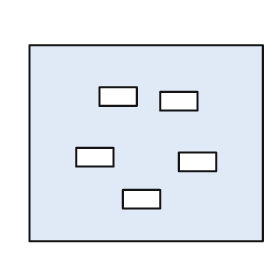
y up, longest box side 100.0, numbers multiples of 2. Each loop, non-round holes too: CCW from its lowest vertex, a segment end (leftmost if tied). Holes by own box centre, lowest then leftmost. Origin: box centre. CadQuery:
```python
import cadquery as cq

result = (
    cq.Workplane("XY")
    .moveTo(-50.0, -42.0)
    .lineTo(50.0, -42.0)
    .lineTo(50.0, 42.0)
    .lineTo(-50.0, 42.0)
    .close()
    .moveTo(-10.0, -28.0)
    .lineTo(6.0, -28.0)
    .lineTo(6.0, -20.0)
    .lineTo(-10.0, -20.0)
    .close()
    .moveTo(14.0, -12.0)
    .lineTo(30.0, -12.0)
    .lineTo(30.0, -4.0)
    .lineTo(14.0, -4.0)
    .close()
    .moveTo(-30.0, -10.0)
    .lineTo(-14.0, -10.0)
    .lineTo(-14.0, -2.0)
    .lineTo(-30.0, -2.0)
    .close()
    .moveTo(6.0, 14.0)
    .lineTo(22.0, 14.0)
    .lineTo(22.0, 22.0)
    .lineTo(6.0, 22.0)
    .close()
    .moveTo(-20.0, 16.0)
    .lineTo(-4.0, 16.0)
    .lineTo(-4.0, 24.0)
    .lineTo(-20.0, 24.0)
    .close()
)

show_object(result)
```